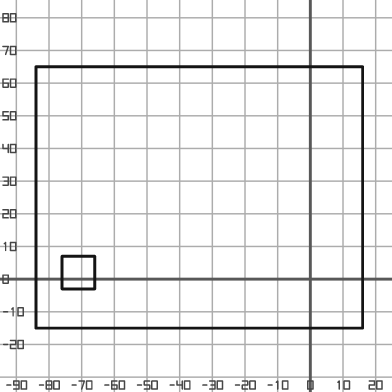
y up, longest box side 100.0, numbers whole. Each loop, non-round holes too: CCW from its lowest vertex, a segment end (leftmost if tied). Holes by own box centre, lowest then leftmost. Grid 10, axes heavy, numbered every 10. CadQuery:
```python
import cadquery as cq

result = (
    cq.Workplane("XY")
    .moveTo(-84.0, -15.0)
    .lineTo(16.0, -15.0)
    .lineTo(16.0, 65.0)
    .lineTo(-84.0, 65.0)
    .close()
    .moveTo(-76.0, -3.0)
    .lineTo(-66.0, -3.0)
    .lineTo(-66.0, 7.0)
    .lineTo(-76.0, 7.0)
    .close()
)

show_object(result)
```